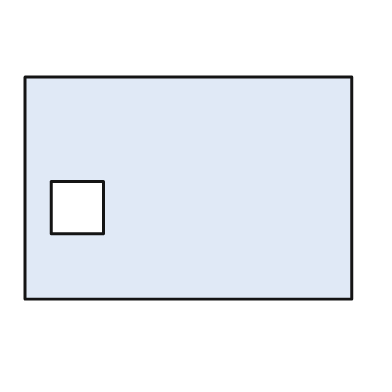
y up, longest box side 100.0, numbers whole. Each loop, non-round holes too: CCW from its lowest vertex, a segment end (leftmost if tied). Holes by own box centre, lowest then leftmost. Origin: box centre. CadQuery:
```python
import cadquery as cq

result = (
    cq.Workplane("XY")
    .moveTo(-50.0, -34.0)
    .lineTo(50.0, -34.0)
    .lineTo(50.0, 34.0)
    .lineTo(-50.0, 34.0)
    .close()
    .moveTo(-42.0, -14.0)
    .lineTo(-26.0, -14.0)
    .lineTo(-26.0, 2.0)
    .lineTo(-42.0, 2.0)
    .close()
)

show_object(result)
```